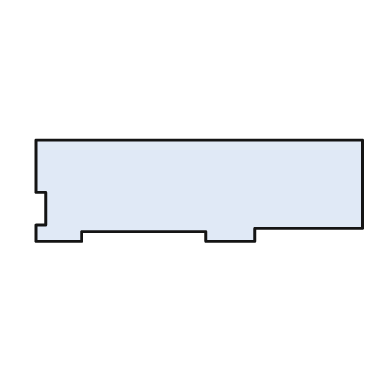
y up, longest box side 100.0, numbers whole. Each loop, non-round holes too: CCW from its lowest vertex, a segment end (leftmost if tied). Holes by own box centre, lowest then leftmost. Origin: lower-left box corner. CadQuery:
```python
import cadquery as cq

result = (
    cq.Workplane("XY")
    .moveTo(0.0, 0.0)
    .lineTo(14.0, 0.0)
    .lineTo(14.0, 3.0)
    .lineTo(52.0, 3.0)
    .lineTo(52.0, 0.0)
    .lineTo(67.0, 0.0)
    .lineTo(67.0, 4.0)
    .lineTo(100.0, 4.0)
    .lineTo(100.0, 31.0)
    .lineTo(0.0, 31.0)
    .lineTo(0.0, 15.0)
    .lineTo(3.0, 15.0)
    .lineTo(3.0, 5.0)
    .lineTo(0.0, 5.0)
    .close()
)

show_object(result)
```